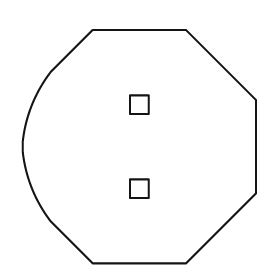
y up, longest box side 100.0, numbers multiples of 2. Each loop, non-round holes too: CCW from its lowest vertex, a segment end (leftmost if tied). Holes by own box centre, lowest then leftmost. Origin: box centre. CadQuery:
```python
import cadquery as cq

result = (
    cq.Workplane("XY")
    .moveTo(-20.0, -50.0)
    .lineTo(20.0, -50.0)
    .lineTo(50.0, -20.0)
    .lineTo(50.0, 20.0)
    .lineTo(20.0, 50.0)
    .lineTo(-20.0, 50.0)
    .lineTo(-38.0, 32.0)
    .threePointArc((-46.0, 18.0), (-50.0, 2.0))
    .lineTo(-50.0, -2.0)
    .threePointArc((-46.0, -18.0), (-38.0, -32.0))
    .close()
    .moveTo(-4.0, -22.0)
    .lineTo(4.0, -22.0)
    .lineTo(4.0, -14.0)
    .lineTo(-4.0, -14.0)
    .close()
    .moveTo(-4.0, 14.0)
    .lineTo(4.0, 14.0)
    .lineTo(4.0, 22.0)
    .lineTo(-4.0, 22.0)
    .close()
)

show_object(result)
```